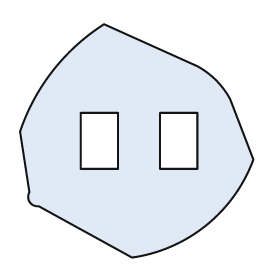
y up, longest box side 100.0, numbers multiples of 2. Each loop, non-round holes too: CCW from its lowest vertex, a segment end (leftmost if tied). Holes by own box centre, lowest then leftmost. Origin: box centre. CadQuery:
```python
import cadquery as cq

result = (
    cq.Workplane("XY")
    .moveTo(-2.0, -50.0)
    .threePointArc((30.0, -36.0), (50.0, -8.0))
    .lineTo(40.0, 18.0)
    .threePointArc((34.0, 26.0), (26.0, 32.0))
    .lineTo(-14.0, 50.0)
    .threePointArc((-36.0, 30.0), (-50.0, 4.0))
    .lineTo(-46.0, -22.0)
    .threePointArc((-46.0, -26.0), (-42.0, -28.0))
    .close()
    .moveTo(-24.0, -12.0)
    .lineTo(-8.0, -12.0)
    .lineTo(-8.0, 12.0)
    .lineTo(-24.0, 12.0)
    .close()
    .moveTo(10.0, -12.0)
    .lineTo(26.0, -12.0)
    .lineTo(26.0, 12.0)
    .lineTo(10.0, 12.0)
    .close()
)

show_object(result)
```